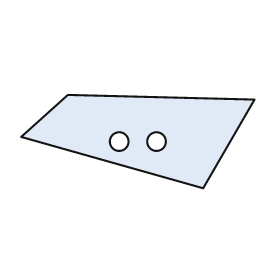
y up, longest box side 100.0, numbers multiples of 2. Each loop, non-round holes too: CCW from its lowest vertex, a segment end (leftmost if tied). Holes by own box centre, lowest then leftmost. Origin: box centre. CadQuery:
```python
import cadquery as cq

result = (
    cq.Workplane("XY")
    .moveTo(28.0, -20.0)
    .lineTo(50.0, 18.0)
    .lineTo(-30.0, 20.0)
    .lineTo(-50.0, 2.0)
    .close()
    .moveTo(-8.0, 0.0)
    .circle(4.0)
    .moveTo(8.0, 0.0)
    .circle(4.0)
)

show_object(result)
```